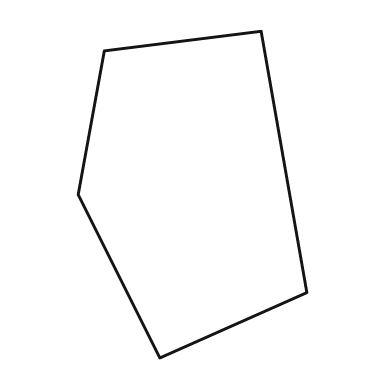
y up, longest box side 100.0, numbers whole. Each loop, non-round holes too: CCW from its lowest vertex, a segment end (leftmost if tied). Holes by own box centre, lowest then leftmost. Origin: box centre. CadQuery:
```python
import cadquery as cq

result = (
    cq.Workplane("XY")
    .moveTo(-10.0, -50.0)
    .lineTo(35.0, -30.0)
    .lineTo(21.0, 50.0)
    .lineTo(-27.0, 44.0)
    .lineTo(-35.0, 0.0)
    .close()
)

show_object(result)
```